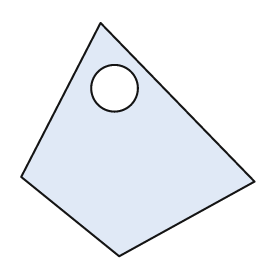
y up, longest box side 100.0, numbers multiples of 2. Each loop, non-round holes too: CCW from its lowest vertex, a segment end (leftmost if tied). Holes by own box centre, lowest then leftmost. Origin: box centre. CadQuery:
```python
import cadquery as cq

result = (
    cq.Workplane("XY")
    .moveTo(-8.0, -50.0)
    .lineTo(50.0, -18.0)
    .lineTo(-16.0, 50.0)
    .lineTo(-50.0, -16.0)
    .close()
    .moveTo(-10.0, 22.0)
    .circle(10.0)
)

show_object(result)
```